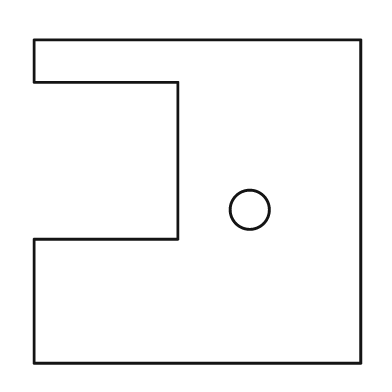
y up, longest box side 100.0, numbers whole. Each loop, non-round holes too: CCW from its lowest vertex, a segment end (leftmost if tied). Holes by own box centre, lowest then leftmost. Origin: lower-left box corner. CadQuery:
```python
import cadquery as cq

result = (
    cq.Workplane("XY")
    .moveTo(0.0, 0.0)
    .lineTo(100.0, 0.0)
    .lineTo(100.0, 99.0)
    .lineTo(0.0, 99.0)
    .lineTo(0.0, 86.0)
    .lineTo(44.0, 86.0)
    .lineTo(44.0, 38.0)
    .lineTo(0.0, 38.0)
    .close()
    .moveTo(66.0, 47.0)
    .circle(6.0)
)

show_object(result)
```